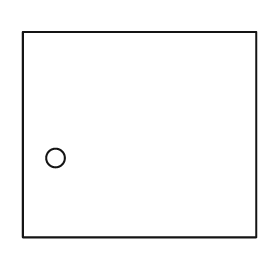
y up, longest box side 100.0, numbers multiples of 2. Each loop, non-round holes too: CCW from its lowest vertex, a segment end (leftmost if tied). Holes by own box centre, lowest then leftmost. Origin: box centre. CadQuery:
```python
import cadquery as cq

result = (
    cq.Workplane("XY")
    .moveTo(-50.0, -44.0)
    .lineTo(50.0, -44.0)
    .lineTo(50.0, 44.0)
    .lineTo(-50.0, 44.0)
    .close()
    .moveTo(-36.0, -10.0)
    .circle(4.0)
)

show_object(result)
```